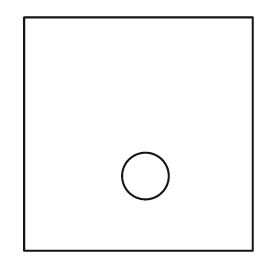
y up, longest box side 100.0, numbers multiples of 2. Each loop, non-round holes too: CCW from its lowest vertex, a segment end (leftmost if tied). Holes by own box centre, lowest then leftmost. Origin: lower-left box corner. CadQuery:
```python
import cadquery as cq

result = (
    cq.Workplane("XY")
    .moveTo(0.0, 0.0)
    .lineTo(98.0, 0.0)
    .lineTo(98.0, 100.0)
    .lineTo(0.0, 100.0)
    .close()
    .moveTo(52.0, 32.0)
    .circle(10.0)
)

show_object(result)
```